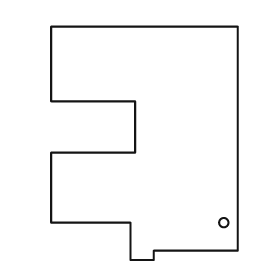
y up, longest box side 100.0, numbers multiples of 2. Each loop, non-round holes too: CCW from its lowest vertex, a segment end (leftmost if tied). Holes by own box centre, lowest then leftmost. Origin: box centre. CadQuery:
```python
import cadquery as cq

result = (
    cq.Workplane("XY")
    .moveTo(-6.0, -50.0)
    .lineTo(4.0, -50.0)
    .lineTo(4.0, -46.0)
    .lineTo(40.0, -46.0)
    .lineTo(40.0, 50.0)
    .lineTo(-40.0, 50.0)
    .lineTo(-40.0, 18.0)
    .lineTo(-4.0, 18.0)
    .lineTo(-4.0, -4.0)
    .lineTo(-40.0, -4.0)
    .lineTo(-40.0, -34.0)
    .lineTo(-6.0, -34.0)
    .close()
    .moveTo(34.0, -34.0)
    .circle(2.0)
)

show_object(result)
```